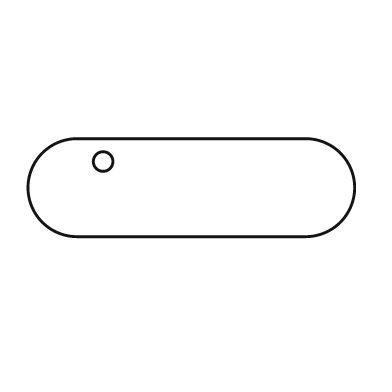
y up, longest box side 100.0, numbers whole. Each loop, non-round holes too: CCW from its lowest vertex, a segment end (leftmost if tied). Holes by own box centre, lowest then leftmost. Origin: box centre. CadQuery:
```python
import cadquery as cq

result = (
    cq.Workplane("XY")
    .moveTo(-35.0, -15.0)
    .lineTo(35.0, -15.0)
    .threePointArc((50.0, 0.0), (35.0, 15.0))
    .lineTo(-35.0, 15.0)
    .threePointArc((-50.0, 0.0), (-35.0, -15.0))
    .close()
    .moveTo(-27.0, 8.0)
    .circle(3.0)
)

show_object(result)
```